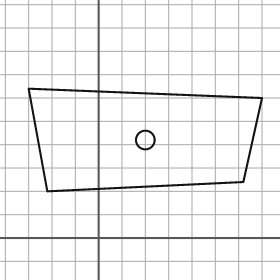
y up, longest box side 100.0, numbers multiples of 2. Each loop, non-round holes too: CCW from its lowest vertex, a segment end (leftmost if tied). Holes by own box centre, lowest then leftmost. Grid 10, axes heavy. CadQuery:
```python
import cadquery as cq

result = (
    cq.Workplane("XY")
    .moveTo(-22.0, 20.0)
    .lineTo(62.0, 24.0)
    .lineTo(70.0, 60.0)
    .lineTo(-30.0, 64.0)
    .close()
    .moveTo(20.0, 42.0)
    .circle(4.0)
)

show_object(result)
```